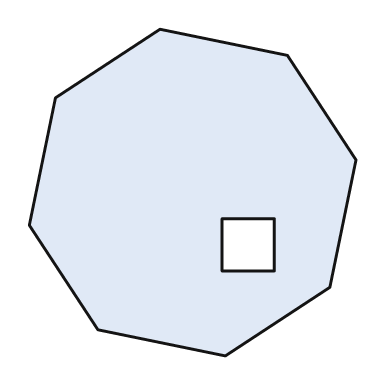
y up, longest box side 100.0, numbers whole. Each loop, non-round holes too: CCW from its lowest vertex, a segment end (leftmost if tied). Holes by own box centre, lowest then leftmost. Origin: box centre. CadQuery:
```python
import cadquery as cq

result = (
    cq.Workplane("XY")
    .moveTo(10.0, -50.0)
    .lineTo(42.0, -29.0)
    .lineTo(50.0, 10.0)
    .lineTo(29.0, 42.0)
    .lineTo(-10.0, 50.0)
    .lineTo(-42.0, 29.0)
    .lineTo(-50.0, -10.0)
    .lineTo(-29.0, -42.0)
    .close()
    .moveTo(9.0, -24.0)
    .lineTo(25.0, -24.0)
    .lineTo(25.0, -8.0)
    .lineTo(9.0, -8.0)
    .close()
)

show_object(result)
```